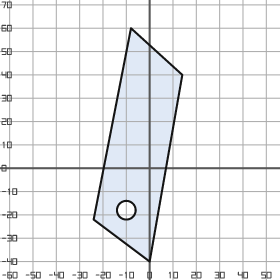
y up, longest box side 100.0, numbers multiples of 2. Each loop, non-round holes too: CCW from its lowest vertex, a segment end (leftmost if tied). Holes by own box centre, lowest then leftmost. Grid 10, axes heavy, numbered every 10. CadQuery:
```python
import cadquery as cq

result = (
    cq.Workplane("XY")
    .moveTo(0.0, -40.0)
    .lineTo(14.0, 40.0)
    .lineTo(-8.0, 60.0)
    .lineTo(-24.0, -22.0)
    .close()
    .moveTo(-10.0, -18.0)
    .circle(4.0)
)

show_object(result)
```